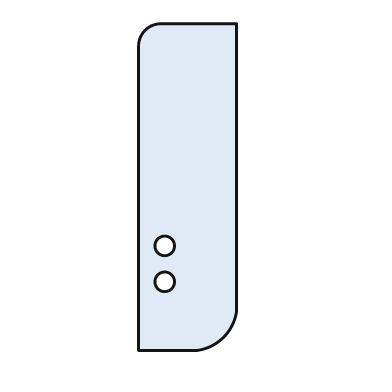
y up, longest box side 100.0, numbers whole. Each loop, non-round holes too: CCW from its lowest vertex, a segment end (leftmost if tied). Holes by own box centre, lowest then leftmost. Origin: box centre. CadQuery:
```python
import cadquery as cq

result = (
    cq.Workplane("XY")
    .moveTo(-15.0, -50.0)
    .lineTo(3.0, -50.0)
    .threePointArc((11.0, -46.0), (15.0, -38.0))
    .lineTo(15.0, 50.0)
    .lineTo(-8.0, 50.0)
    .threePointArc((-13.0, 48.0), (-15.0, 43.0))
    .close()
    .moveTo(-7.0, -29.0)
    .circle(3.0)
    .moveTo(-7.0, -18.0)
    .circle(3.0)
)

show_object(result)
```